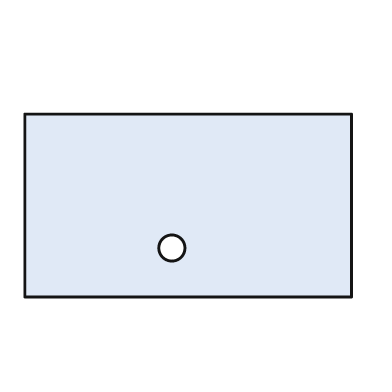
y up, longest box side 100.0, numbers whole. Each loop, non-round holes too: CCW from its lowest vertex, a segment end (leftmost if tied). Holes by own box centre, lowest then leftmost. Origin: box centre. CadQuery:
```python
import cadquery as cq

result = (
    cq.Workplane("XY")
    .moveTo(-50.0, -28.0)
    .lineTo(50.0, -28.0)
    .lineTo(50.0, 28.0)
    .lineTo(-50.0, 28.0)
    .close()
    .moveTo(-5.0, -13.0)
    .circle(4.0)
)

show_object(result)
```